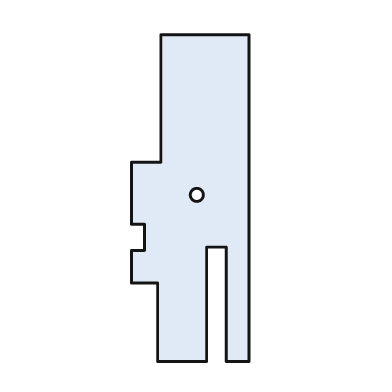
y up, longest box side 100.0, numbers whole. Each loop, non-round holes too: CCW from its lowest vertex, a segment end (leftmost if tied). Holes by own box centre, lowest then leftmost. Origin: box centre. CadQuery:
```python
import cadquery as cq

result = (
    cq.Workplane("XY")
    .moveTo(-10.0, -50.0)
    .lineTo(5.0, -50.0)
    .lineTo(5.0, -15.0)
    .lineTo(11.0, -15.0)
    .lineTo(11.0, -50.0)
    .lineTo(18.0, -50.0)
    .lineTo(18.0, 50.0)
    .lineTo(-9.0, 50.0)
    .lineTo(-9.0, 11.0)
    .lineTo(-18.0, 11.0)
    .lineTo(-18.0, -8.0)
    .lineTo(-14.0, -8.0)
    .lineTo(-14.0, -16.0)
    .lineTo(-18.0, -16.0)
    .lineTo(-18.0, -26.0)
    .lineTo(-10.0, -26.0)
    .close()
    .moveTo(2.0, 1.0)
    .circle(2.0)
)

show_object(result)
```